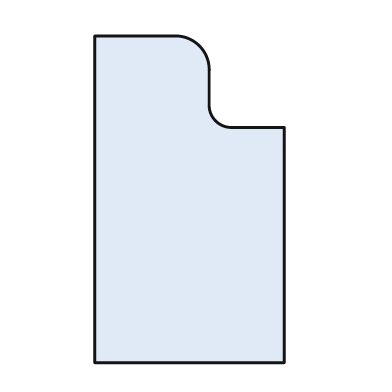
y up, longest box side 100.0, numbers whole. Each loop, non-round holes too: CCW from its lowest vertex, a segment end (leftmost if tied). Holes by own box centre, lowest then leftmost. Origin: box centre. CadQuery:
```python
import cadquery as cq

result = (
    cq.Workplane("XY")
    .moveTo(-29.0, -50.0)
    .lineTo(29.0, -50.0)
    .lineTo(29.0, 22.0)
    .lineTo(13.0, 22.0)
    .threePointArc((8.0, 24.0), (6.0, 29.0))
    .lineTo(6.0, 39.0)
    .threePointArc((3.0, 47.0), (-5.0, 50.0))
    .lineTo(-29.0, 50.0)
    .close()
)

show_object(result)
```